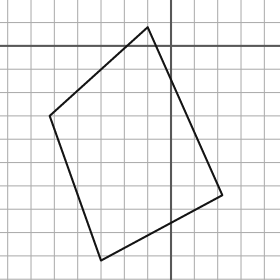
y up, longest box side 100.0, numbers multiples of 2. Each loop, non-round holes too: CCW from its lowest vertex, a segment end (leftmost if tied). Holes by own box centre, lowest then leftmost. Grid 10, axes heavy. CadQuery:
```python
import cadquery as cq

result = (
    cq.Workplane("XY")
    .moveTo(-30.0, -92.0)
    .lineTo(22.0, -64.0)
    .lineTo(-10.0, 8.0)
    .lineTo(-52.0, -30.0)
    .close()
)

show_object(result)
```